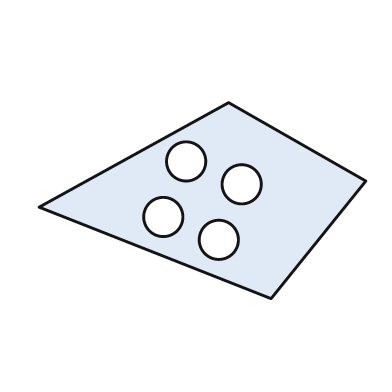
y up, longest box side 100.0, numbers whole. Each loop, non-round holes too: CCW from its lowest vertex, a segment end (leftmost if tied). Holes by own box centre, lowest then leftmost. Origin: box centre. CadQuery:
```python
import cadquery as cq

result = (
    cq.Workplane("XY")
    .moveTo(21.0, -30.0)
    .lineTo(50.0, 6.0)
    .lineTo(8.0, 30.0)
    .lineTo(-50.0, -2.0)
    .close()
    .moveTo(5.0, -12.0)
    .circle(6.0)
    .moveTo(-12.0, -5.0)
    .circle(6.0)
    .moveTo(12.0, 5.0)
    .circle(6.0)
    .moveTo(-5.0, 12.0)
    .circle(6.0)
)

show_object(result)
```